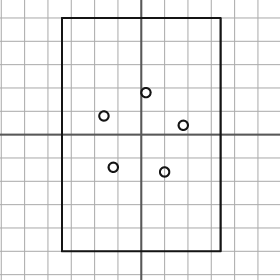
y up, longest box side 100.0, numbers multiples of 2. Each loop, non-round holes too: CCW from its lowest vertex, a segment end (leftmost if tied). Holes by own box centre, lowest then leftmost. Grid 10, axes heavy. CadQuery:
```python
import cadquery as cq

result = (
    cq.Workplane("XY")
    .moveTo(-34.0, -50.0)
    .lineTo(34.0, -50.0)
    .lineTo(34.0, 50.0)
    .lineTo(-34.0, 50.0)
    .close()
    .moveTo(10.0, -16.0)
    .circle(2.0)
    .moveTo(-12.0, -14.0)
    .circle(2.0)
    .moveTo(18.0, 4.0)
    .circle(2.0)
    .moveTo(-16.0, 8.0)
    .circle(2.0)
    .moveTo(2.0, 18.0)
    .circle(2.0)
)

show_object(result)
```